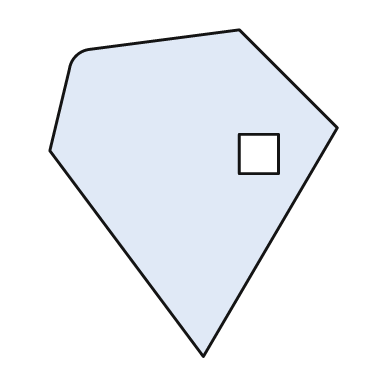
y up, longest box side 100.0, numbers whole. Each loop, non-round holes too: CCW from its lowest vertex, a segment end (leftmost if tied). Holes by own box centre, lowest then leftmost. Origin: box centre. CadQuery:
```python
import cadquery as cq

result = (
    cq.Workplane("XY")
    .moveTo(3.0, -50.0)
    .lineTo(44.0, 20.0)
    .lineTo(14.0, 50.0)
    .lineTo(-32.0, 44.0)
    .threePointArc((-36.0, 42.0), (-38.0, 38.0))
    .lineTo(-44.0, 13.0)
    .close()
    .moveTo(14.0, 6.0)
    .lineTo(26.0, 6.0)
    .lineTo(26.0, 18.0)
    .lineTo(14.0, 18.0)
    .close()
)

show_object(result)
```